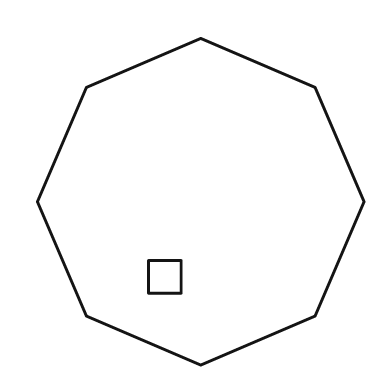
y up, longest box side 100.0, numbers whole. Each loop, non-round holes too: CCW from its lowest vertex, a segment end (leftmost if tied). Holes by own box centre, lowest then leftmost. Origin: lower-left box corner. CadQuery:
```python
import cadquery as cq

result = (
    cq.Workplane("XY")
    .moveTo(50.0, 0.0)
    .lineTo(85.0, 15.0)
    .lineTo(100.0, 50.0)
    .lineTo(85.0, 85.0)
    .lineTo(50.0, 100.0)
    .lineTo(15.0, 85.0)
    .lineTo(0.0, 50.0)
    .lineTo(15.0, 15.0)
    .close()
    .moveTo(34.0, 22.0)
    .lineTo(44.0, 22.0)
    .lineTo(44.0, 32.0)
    .lineTo(34.0, 32.0)
    .close()
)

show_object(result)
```